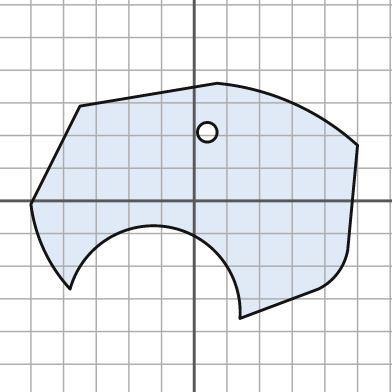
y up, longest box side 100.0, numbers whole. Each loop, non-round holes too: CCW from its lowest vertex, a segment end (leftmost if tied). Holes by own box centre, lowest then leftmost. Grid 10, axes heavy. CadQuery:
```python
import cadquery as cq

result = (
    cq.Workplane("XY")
    .moveTo(14.0, -36.0)
    .lineTo(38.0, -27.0)
    .threePointArc((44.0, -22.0), (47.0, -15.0))
    .lineTo(50.0, 17.0)
    .threePointArc((30.0, 30.0), (7.0, 36.0))
    .lineTo(-35.0, 29.0)
    .lineTo(-50.0, -1.0)
    .threePointArc((-46.0, -15.0), (-38.0, -27.0))
    .threePointArc((-8.0, -8.0), (14.0, -36.0))
    .close()
    .moveTo(4.0, 21.0)
    .circle(3.0)
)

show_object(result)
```